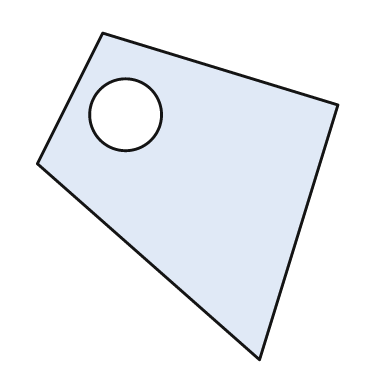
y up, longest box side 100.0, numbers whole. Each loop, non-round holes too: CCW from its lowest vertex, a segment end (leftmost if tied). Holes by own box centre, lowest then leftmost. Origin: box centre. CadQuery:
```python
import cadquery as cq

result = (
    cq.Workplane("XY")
    .moveTo(22.0, -50.0)
    .lineTo(46.0, 28.0)
    .lineTo(-26.0, 50.0)
    .lineTo(-46.0, 10.0)
    .close()
    .moveTo(-19.0, 25.0)
    .circle(11.0)
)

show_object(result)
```